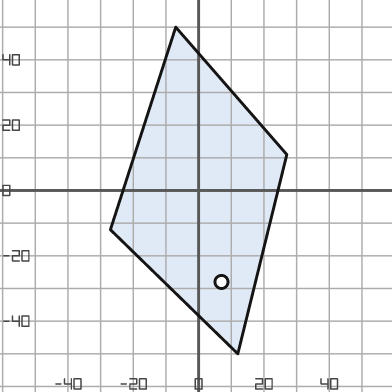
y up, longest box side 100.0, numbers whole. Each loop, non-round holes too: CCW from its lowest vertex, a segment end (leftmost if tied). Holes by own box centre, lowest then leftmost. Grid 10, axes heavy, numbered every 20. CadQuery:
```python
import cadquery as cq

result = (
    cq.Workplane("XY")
    .moveTo(12.0, -50.0)
    .lineTo(27.0, 11.0)
    .lineTo(-7.0, 50.0)
    .lineTo(-27.0, -12.0)
    .close()
    .moveTo(7.0, -28.0)
    .circle(2.0)
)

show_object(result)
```